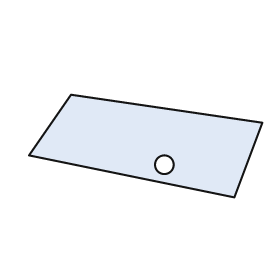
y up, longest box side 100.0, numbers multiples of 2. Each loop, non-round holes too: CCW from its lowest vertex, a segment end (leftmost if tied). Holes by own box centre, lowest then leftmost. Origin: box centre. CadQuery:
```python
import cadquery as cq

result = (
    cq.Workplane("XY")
    .moveTo(38.0, -22.0)
    .lineTo(50.0, 10.0)
    .lineTo(-32.0, 22.0)
    .lineTo(-50.0, -4.0)
    .close()
    .moveTo(8.0, -8.0)
    .circle(4.0)
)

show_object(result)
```